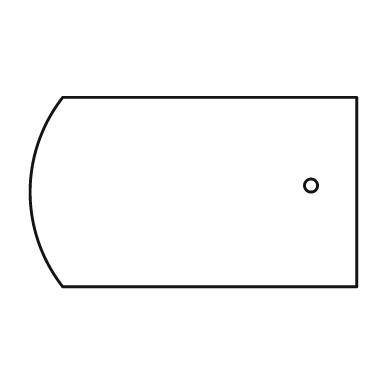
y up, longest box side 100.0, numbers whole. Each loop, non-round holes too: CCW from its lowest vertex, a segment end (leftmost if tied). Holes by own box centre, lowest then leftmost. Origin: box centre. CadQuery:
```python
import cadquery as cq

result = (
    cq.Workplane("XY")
    .moveTo(-40.0, -29.0)
    .lineTo(50.0, -29.0)
    .lineTo(50.0, 29.0)
    .lineTo(-40.0, 29.0)
    .threePointArc((-50.0, 0.0), (-40.0, -29.0))
    .close()
    .moveTo(36.0, 2.0)
    .circle(2.0)
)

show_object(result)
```